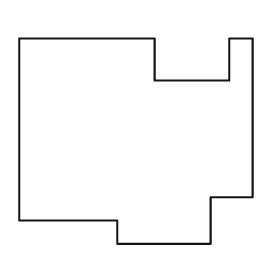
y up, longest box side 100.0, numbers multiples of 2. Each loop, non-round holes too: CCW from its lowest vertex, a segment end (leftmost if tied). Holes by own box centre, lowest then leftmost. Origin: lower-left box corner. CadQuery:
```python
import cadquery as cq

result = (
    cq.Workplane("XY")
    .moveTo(42.0, 0.0)
    .lineTo(82.0, 0.0)
    .lineTo(82.0, 20.0)
    .lineTo(100.0, 20.0)
    .lineTo(100.0, 88.0)
    .lineTo(90.0, 88.0)
    .lineTo(90.0, 70.0)
    .lineTo(58.0, 70.0)
    .lineTo(58.0, 88.0)
    .lineTo(0.0, 88.0)
    .lineTo(0.0, 10.0)
    .lineTo(42.0, 10.0)
    .close()
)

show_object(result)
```